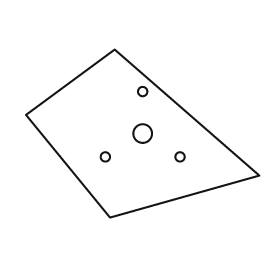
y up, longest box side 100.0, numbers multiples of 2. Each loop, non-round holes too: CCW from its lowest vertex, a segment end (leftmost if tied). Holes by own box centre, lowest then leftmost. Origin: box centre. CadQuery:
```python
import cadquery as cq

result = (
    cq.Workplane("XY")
    .moveTo(-14.0, -36.0)
    .lineTo(50.0, -18.0)
    .lineTo(-12.0, 36.0)
    .lineTo(-50.0, 8.0)
    .close()
    .moveTo(-16.0, -10.0)
    .circle(2.0)
    .moveTo(16.0, -10.0)
    .circle(2.0)
    .moveTo(0.0, 0.0)
    .circle(4.0)
    .moveTo(0.0, 18.0)
    .circle(2.0)
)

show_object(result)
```